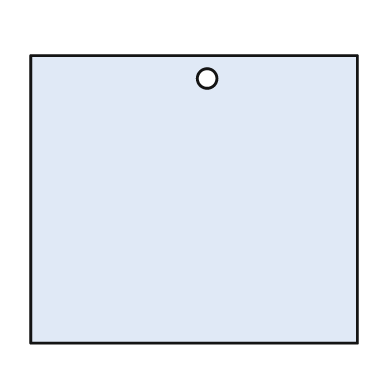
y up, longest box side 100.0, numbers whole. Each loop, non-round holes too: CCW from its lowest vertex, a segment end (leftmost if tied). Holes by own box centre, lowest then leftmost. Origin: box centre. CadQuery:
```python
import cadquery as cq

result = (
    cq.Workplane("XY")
    .moveTo(-50.0, -44.0)
    .lineTo(50.0, -44.0)
    .lineTo(50.0, 44.0)
    .lineTo(-50.0, 44.0)
    .close()
    .moveTo(4.0, 37.0)
    .circle(3.0)
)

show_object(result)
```